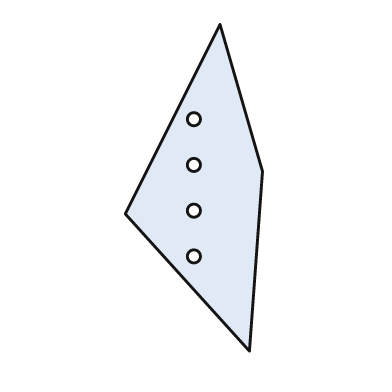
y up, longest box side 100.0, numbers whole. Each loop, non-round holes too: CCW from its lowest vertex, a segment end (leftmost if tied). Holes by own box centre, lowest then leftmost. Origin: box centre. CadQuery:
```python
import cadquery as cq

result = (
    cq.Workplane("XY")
    .moveTo(17.0, -50.0)
    .lineTo(21.0, 5.0)
    .lineTo(8.0, 50.0)
    .lineTo(-21.0, -8.0)
    .close()
    .moveTo(0.0, -21.0)
    .circle(2.0)
    .moveTo(0.0, -7.0)
    .circle(2.0)
    .moveTo(0.0, 7.0)
    .circle(2.0)
    .moveTo(0.0, 21.0)
    .circle(2.0)
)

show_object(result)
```